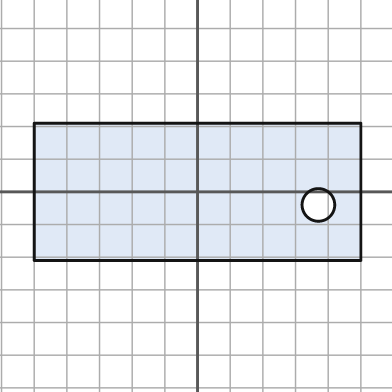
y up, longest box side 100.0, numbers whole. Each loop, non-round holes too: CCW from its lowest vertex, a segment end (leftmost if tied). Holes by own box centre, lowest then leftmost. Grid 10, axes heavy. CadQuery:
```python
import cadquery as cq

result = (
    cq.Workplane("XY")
    .moveTo(-50.0, -21.0)
    .lineTo(50.0, -21.0)
    .lineTo(50.0, 21.0)
    .lineTo(-50.0, 21.0)
    .close()
    .moveTo(37.0, -4.0)
    .circle(5.0)
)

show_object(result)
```